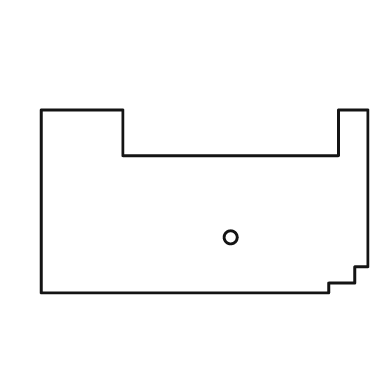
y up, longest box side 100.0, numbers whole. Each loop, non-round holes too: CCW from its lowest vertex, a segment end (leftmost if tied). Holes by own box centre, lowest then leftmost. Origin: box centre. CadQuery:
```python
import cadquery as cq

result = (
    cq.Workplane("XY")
    .moveTo(-50.0, -28.0)
    .lineTo(38.0, -28.0)
    .lineTo(38.0, -25.0)
    .lineTo(46.0, -25.0)
    .lineTo(46.0, -20.0)
    .lineTo(50.0, -20.0)
    .lineTo(50.0, 28.0)
    .lineTo(41.0, 28.0)
    .lineTo(41.0, 14.0)
    .lineTo(-25.0, 14.0)
    .lineTo(-25.0, 28.0)
    .lineTo(-50.0, 28.0)
    .close()
    .moveTo(8.0, -11.0)
    .circle(2.0)
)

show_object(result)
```